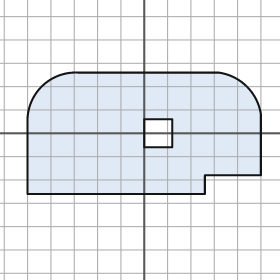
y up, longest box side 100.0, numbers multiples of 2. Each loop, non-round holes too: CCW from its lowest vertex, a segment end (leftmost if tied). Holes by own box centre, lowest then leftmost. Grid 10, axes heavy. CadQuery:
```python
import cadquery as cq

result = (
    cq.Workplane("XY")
    .moveTo(-50.0, -26.0)
    .lineTo(26.0, -26.0)
    .lineTo(26.0, -18.0)
    .lineTo(50.0, -18.0)
    .lineTo(50.0, 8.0)
    .threePointArc((44.0, 20.0), (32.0, 26.0))
    .lineTo(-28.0, 26.0)
    .threePointArc((-44.0, 20.0), (-50.0, 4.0))
    .close()
    .moveTo(0.0, -6.0)
    .lineTo(12.0, -6.0)
    .lineTo(12.0, 6.0)
    .lineTo(0.0, 6.0)
    .close()
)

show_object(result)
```